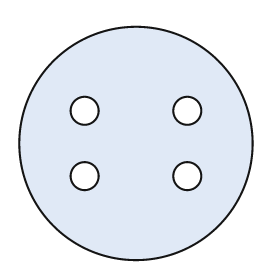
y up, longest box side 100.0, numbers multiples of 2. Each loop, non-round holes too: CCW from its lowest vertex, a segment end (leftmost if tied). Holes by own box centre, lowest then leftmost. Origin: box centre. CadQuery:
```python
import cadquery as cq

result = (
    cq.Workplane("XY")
    .moveTo(0.0, 0.0)
    .circle(50.0)
    .moveTo(-22.0, -14.0)
    .circle(6.0)
    .moveTo(22.0, -14.0)
    .circle(6.0)
    .moveTo(-22.0, 14.0)
    .circle(6.0)
    .moveTo(22.0, 14.0)
    .circle(6.0)
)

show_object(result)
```